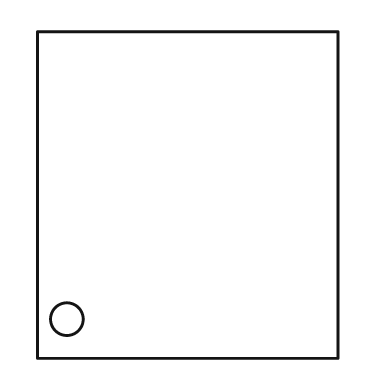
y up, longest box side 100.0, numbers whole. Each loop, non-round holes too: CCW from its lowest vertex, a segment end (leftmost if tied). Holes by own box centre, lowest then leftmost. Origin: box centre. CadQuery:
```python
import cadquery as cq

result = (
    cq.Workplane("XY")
    .moveTo(-46.0, -50.0)
    .lineTo(46.0, -50.0)
    .lineTo(46.0, 50.0)
    .lineTo(-46.0, 50.0)
    .close()
    .moveTo(-37.0, -38.0)
    .circle(5.0)
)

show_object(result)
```